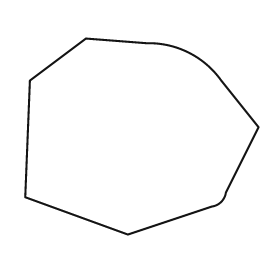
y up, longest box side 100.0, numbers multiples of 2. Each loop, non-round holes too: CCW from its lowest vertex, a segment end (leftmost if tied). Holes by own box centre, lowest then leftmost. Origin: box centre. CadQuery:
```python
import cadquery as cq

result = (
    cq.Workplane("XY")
    .moveTo(-6.0, -42.0)
    .lineTo(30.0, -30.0)
    .threePointArc((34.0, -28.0), (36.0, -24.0))
    .lineTo(50.0, 4.0)
    .lineTo(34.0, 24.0)
    .threePointArc((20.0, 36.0), (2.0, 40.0))
    .lineTo(-24.0, 42.0)
    .lineTo(-48.0, 24.0)
    .lineTo(-50.0, -26.0)
    .close()
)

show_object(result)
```